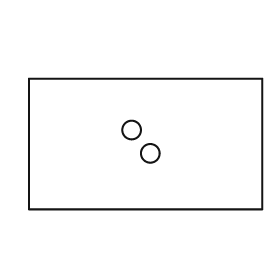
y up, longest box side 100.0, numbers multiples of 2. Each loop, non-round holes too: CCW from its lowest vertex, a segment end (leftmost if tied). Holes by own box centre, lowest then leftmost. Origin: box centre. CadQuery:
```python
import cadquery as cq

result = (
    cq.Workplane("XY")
    .moveTo(-50.0, -28.0)
    .lineTo(50.0, -28.0)
    .lineTo(50.0, 28.0)
    .lineTo(-50.0, 28.0)
    .close()
    .moveTo(2.0, -4.0)
    .circle(4.0)
    .moveTo(-6.0, 6.0)
    .circle(4.0)
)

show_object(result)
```